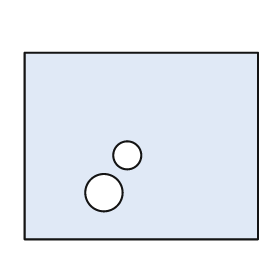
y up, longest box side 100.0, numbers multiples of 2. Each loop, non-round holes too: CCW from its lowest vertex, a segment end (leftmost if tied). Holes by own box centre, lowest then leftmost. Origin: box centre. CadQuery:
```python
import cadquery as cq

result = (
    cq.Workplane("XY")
    .moveTo(-50.0, -40.0)
    .lineTo(50.0, -40.0)
    .lineTo(50.0, 40.0)
    .lineTo(-50.0, 40.0)
    .close()
    .moveTo(-16.0, -20.0)
    .circle(8.0)
    .moveTo(-6.0, -4.0)
    .circle(6.0)
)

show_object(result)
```